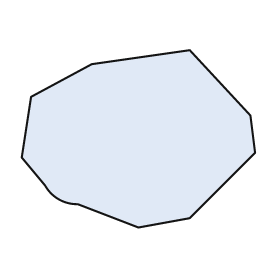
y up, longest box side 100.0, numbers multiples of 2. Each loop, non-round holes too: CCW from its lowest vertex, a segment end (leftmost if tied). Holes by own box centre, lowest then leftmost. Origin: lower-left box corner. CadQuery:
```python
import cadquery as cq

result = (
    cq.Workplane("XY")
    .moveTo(50.0, 0.0)
    .lineTo(72.0, 4.0)
    .lineTo(100.0, 32.0)
    .lineTo(98.0, 48.0)
    .lineTo(72.0, 76.0)
    .lineTo(30.0, 70.0)
    .lineTo(4.0, 56.0)
    .lineTo(0.0, 30.0)
    .lineTo(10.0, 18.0)
    .threePointArc((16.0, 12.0), (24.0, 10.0))
    .close()
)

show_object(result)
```